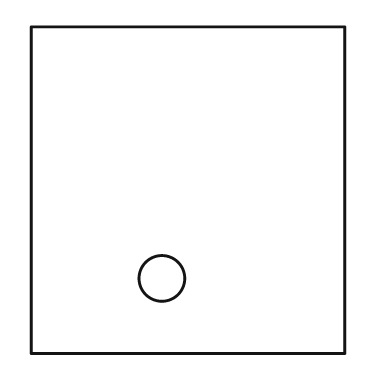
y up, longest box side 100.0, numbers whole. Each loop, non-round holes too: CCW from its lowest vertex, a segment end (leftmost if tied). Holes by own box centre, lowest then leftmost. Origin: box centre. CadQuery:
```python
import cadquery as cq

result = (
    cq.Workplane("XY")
    .moveTo(-48.0, -50.0)
    .lineTo(48.0, -50.0)
    .lineTo(48.0, 50.0)
    .lineTo(-48.0, 50.0)
    .close()
    .moveTo(-8.0, -27.0)
    .circle(7.0)
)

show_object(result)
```